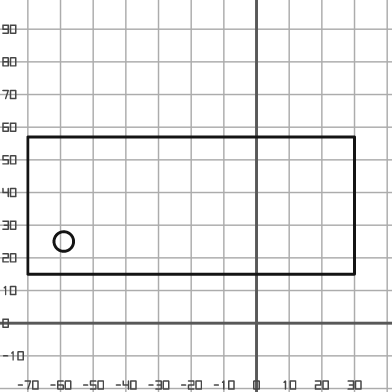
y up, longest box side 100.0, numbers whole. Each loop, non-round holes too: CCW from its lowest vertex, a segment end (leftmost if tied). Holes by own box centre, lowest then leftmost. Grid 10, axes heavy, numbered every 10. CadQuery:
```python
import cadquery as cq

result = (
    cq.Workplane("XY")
    .moveTo(-70.0, 15.0)
    .lineTo(30.0, 15.0)
    .lineTo(30.0, 57.0)
    .lineTo(-70.0, 57.0)
    .close()
    .moveTo(-59.0, 25.0)
    .circle(3.0)
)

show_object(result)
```